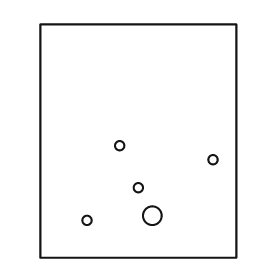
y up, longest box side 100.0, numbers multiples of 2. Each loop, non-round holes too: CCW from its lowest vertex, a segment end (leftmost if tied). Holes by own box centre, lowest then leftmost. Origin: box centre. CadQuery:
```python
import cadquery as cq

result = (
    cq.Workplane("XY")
    .moveTo(-42.0, -50.0)
    .lineTo(42.0, -50.0)
    .lineTo(42.0, 50.0)
    .lineTo(-42.0, 50.0)
    .close()
    .moveTo(-22.0, -34.0)
    .circle(2.0)
    .moveTo(6.0, -32.0)
    .circle(4.0)
    .moveTo(0.0, -20.0)
    .circle(2.0)
    .moveTo(32.0, -8.0)
    .circle(2.0)
    .moveTo(-8.0, -2.0)
    .circle(2.0)
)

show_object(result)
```